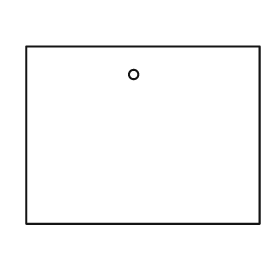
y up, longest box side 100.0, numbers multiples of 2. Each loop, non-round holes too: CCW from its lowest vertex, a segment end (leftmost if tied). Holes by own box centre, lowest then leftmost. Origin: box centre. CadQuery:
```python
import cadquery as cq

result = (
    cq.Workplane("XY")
    .moveTo(-50.0, -38.0)
    .lineTo(50.0, -38.0)
    .lineTo(50.0, 38.0)
    .lineTo(-50.0, 38.0)
    .close()
    .moveTo(-4.0, 26.0)
    .circle(2.0)
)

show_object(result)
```